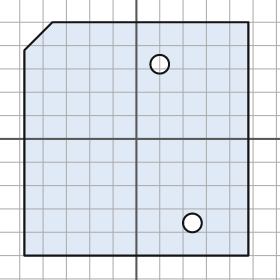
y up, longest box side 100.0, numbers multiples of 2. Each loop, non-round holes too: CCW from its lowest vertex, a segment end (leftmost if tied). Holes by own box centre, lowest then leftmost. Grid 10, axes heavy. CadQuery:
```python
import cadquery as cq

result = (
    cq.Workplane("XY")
    .moveTo(-48.0, -50.0)
    .lineTo(48.0, -50.0)
    .lineTo(48.0, 50.0)
    .lineTo(-36.0, 50.0)
    .lineTo(-48.0, 38.0)
    .close()
    .moveTo(24.0, -36.0)
    .circle(4.0)
    .moveTo(10.0, 32.0)
    .circle(4.0)
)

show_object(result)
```